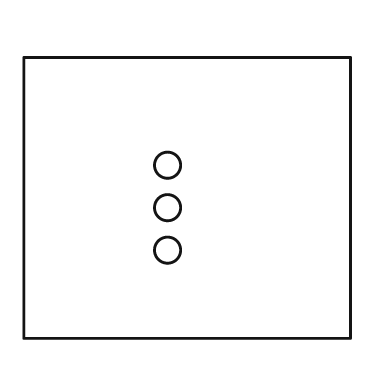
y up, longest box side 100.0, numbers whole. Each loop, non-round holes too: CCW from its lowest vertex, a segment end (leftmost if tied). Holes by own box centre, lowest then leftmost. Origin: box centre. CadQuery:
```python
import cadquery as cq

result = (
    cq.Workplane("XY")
    .moveTo(-50.0, -43.0)
    .lineTo(50.0, -43.0)
    .lineTo(50.0, 43.0)
    .lineTo(-50.0, 43.0)
    .close()
    .moveTo(-6.0, -16.0)
    .circle(4.0)
    .moveTo(-6.0, -3.0)
    .circle(4.0)
    .moveTo(-6.0, 10.0)
    .circle(4.0)
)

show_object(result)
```